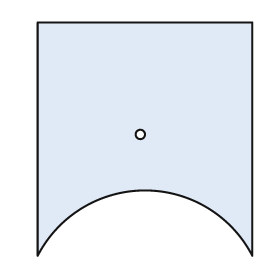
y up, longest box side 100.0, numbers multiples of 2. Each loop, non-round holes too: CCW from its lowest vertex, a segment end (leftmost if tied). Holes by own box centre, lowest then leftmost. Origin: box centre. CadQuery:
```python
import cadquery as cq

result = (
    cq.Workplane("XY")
    .moveTo(-46.0, -50.0)
    .threePointArc((0.0, -22.0), (46.0, -50.0))
    .lineTo(46.0, 50.0)
    .lineTo(-46.0, 50.0)
    .close()
    .moveTo(-2.0, 2.0)
    .circle(2.0)
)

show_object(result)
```